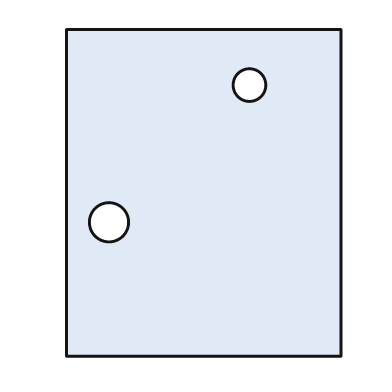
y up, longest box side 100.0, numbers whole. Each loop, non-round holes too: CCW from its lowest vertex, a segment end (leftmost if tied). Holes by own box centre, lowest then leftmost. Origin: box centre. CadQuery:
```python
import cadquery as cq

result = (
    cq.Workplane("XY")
    .moveTo(-42.0, -50.0)
    .lineTo(42.0, -50.0)
    .lineTo(42.0, 50.0)
    .lineTo(-42.0, 50.0)
    .close()
    .moveTo(-29.0, -9.0)
    .circle(6.0)
    .moveTo(14.0, 33.0)
    .circle(5.0)
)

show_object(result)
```